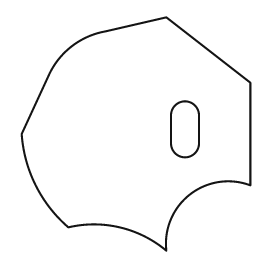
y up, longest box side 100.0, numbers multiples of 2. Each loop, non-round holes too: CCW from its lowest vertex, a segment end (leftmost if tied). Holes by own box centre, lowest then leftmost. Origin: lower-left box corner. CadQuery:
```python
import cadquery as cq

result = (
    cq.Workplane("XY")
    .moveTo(62.0, 0.0)
    .threePointArc((72.0, 24.0), (98.0, 28.0))
    .lineTo(98.0, 72.0)
    .lineTo(62.0, 100.0)
    .lineTo(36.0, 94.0)
    .threePointArc((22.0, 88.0), (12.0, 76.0))
    .lineTo(0.0, 50.0)
    .threePointArc((6.0, 28.0), (20.0, 10.0))
    .threePointArc((42.0, 10.0), (62.0, 0.0))
    .close()
    .moveTo(64.0, 46.0)
    .threePointArc((70.0, 40.0), (76.0, 46.0))
    .lineTo(76.0, 58.0)
    .threePointArc((70.0, 64.0), (64.0, 58.0))
    .close()
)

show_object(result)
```